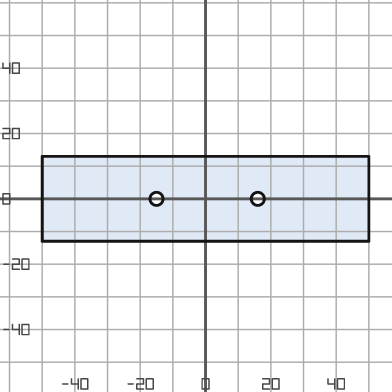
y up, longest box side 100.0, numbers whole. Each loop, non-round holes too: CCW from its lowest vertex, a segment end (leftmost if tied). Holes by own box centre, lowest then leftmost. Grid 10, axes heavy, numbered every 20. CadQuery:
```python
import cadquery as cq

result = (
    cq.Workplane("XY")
    .moveTo(-50.0, -13.0)
    .lineTo(50.0, -13.0)
    .lineTo(50.0, 13.0)
    .lineTo(-50.0, 13.0)
    .close()
    .moveTo(-15.0, 0.0)
    .circle(2.0)
    .moveTo(16.0, 0.0)
    .circle(2.0)
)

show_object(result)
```